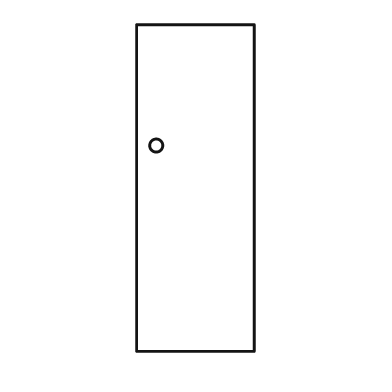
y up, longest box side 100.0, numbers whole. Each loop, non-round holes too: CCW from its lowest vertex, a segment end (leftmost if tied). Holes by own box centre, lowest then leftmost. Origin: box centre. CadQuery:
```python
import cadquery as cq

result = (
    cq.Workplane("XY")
    .moveTo(-18.0, -50.0)
    .lineTo(18.0, -50.0)
    .lineTo(18.0, 50.0)
    .lineTo(-18.0, 50.0)
    .close()
    .moveTo(-12.0, 13.0)
    .circle(2.0)
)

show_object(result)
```